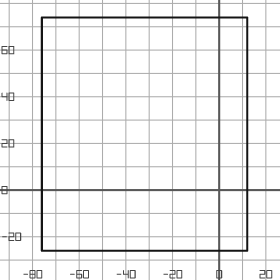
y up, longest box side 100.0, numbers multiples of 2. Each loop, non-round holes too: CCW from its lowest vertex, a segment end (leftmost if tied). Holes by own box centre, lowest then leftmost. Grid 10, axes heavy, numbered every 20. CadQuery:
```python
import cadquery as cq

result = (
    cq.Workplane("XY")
    .moveTo(-76.0, -26.0)
    .lineTo(12.0, -26.0)
    .lineTo(12.0, 74.0)
    .lineTo(-76.0, 74.0)
    .close()
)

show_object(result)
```